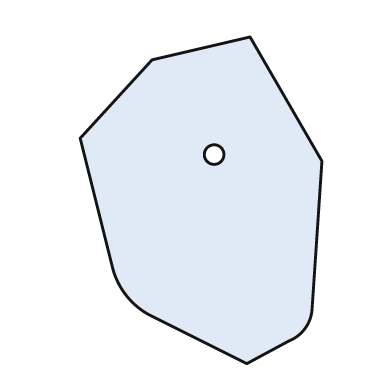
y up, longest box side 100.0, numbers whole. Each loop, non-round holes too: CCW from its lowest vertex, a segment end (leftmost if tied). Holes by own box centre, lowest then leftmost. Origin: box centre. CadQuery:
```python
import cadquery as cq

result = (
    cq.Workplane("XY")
    .moveTo(14.0, -50.0)
    .lineTo(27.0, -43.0)
    .threePointArc((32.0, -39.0), (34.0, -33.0))
    .lineTo(37.0, 12.0)
    .lineTo(15.0, 50.0)
    .lineTo(-15.0, 43.0)
    .lineTo(-37.0, 19.0)
    .lineTo(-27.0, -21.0)
    .threePointArc((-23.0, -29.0), (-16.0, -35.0))
    .close()
    .moveTo(4.0, 14.0)
    .circle(3.0)
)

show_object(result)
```